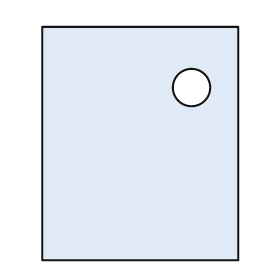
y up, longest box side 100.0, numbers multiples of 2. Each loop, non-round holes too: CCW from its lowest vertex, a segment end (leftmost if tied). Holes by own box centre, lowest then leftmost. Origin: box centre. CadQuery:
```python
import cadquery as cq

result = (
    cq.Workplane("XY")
    .moveTo(-42.0, -50.0)
    .lineTo(42.0, -50.0)
    .lineTo(42.0, 50.0)
    .lineTo(-42.0, 50.0)
    .close()
    .moveTo(22.0, 24.0)
    .circle(8.0)
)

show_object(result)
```